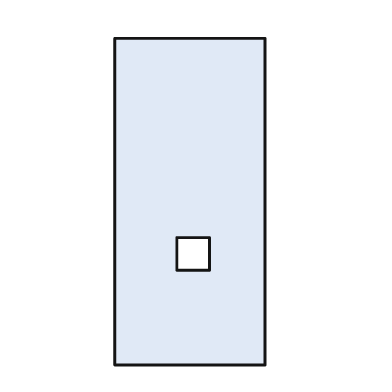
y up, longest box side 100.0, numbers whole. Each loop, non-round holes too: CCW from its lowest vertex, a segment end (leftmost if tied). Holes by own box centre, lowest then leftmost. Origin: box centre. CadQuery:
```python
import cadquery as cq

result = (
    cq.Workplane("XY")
    .moveTo(-23.0, -50.0)
    .lineTo(23.0, -50.0)
    .lineTo(23.0, 50.0)
    .lineTo(-23.0, 50.0)
    .close()
    .moveTo(-4.0, -21.0)
    .lineTo(6.0, -21.0)
    .lineTo(6.0, -11.0)
    .lineTo(-4.0, -11.0)
    .close()
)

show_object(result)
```